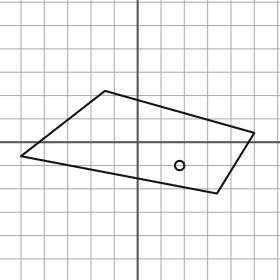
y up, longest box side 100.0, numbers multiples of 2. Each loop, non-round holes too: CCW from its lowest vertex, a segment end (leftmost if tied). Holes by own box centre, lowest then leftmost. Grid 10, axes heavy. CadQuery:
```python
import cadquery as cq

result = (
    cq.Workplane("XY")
    .moveTo(34.0, -22.0)
    .lineTo(50.0, 4.0)
    .lineTo(-14.0, 22.0)
    .lineTo(-50.0, -6.0)
    .close()
    .moveTo(18.0, -10.0)
    .circle(2.0)
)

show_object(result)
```